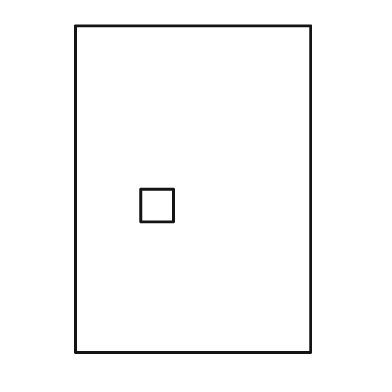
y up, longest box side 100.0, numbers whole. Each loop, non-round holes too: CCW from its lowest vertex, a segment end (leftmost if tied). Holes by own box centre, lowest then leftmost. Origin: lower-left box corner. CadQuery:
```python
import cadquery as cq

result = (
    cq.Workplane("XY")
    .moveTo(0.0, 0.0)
    .lineTo(72.0, 0.0)
    .lineTo(72.0, 100.0)
    .lineTo(0.0, 100.0)
    .close()
    .moveTo(20.0, 40.0)
    .lineTo(30.0, 40.0)
    .lineTo(30.0, 50.0)
    .lineTo(20.0, 50.0)
    .close()
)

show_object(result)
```